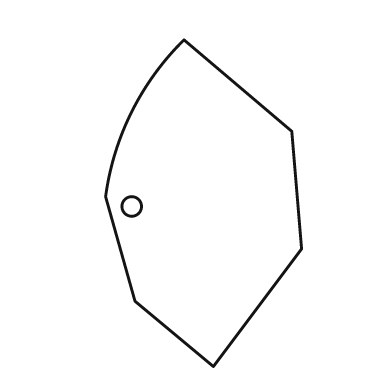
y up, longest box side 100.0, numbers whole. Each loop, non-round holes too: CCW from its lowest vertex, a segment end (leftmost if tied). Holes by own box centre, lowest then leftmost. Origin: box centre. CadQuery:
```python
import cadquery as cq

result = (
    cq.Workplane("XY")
    .moveTo(3.0, -50.0)
    .lineTo(30.0, -14.0)
    .lineTo(27.0, 22.0)
    .lineTo(-6.0, 50.0)
    .threePointArc((-22.0, 28.0), (-30.0, 2.0))
    .lineTo(-21.0, -30.0)
    .close()
    .moveTo(-22.0, -1.0)
    .circle(3.0)
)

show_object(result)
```